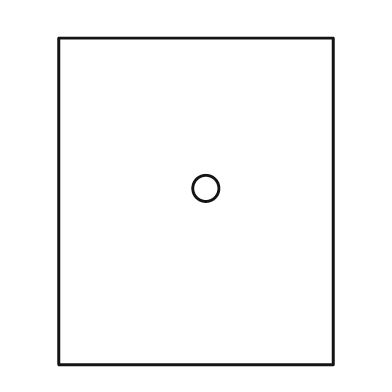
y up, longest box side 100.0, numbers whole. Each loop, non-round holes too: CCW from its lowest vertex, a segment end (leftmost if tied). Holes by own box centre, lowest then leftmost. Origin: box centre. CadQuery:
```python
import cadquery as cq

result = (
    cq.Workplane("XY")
    .moveTo(-42.0, -50.0)
    .lineTo(42.0, -50.0)
    .lineTo(42.0, 50.0)
    .lineTo(-42.0, 50.0)
    .close()
    .moveTo(3.0, 4.0)
    .circle(4.0)
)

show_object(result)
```